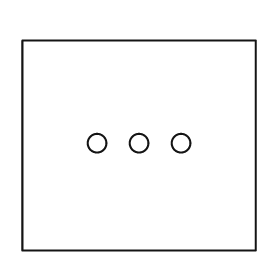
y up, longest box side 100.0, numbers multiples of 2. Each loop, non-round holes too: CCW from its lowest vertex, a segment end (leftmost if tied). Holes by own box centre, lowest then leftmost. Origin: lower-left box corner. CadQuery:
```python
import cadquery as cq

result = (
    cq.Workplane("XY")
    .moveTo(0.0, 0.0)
    .lineTo(100.0, 0.0)
    .lineTo(100.0, 90.0)
    .lineTo(0.0, 90.0)
    .close()
    .moveTo(32.0, 46.0)
    .circle(4.0)
    .moveTo(50.0, 46.0)
    .circle(4.0)
    .moveTo(68.0, 46.0)
    .circle(4.0)
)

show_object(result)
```